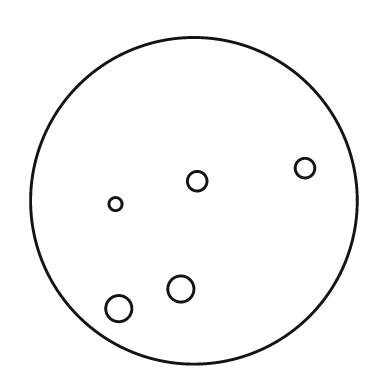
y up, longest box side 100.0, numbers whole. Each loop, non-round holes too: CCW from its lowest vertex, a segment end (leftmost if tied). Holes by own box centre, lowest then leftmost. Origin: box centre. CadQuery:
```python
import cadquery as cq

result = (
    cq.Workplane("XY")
    .moveTo(0.0, 0.0)
    .circle(50.0)
    .moveTo(-23.0, -33.0)
    .circle(4.0)
    .moveTo(-4.0, -27.0)
    .circle(4.0)
    .moveTo(-24.0, -1.0)
    .circle(2.0)
    .moveTo(1.0, 6.0)
    .circle(3.0)
    .moveTo(34.0, 10.0)
    .circle(3.0)
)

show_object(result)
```